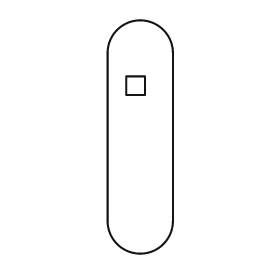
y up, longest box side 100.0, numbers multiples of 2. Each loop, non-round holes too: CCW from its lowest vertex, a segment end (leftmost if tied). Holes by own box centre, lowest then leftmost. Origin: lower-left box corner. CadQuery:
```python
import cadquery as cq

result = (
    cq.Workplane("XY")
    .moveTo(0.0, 14.0)
    .threePointArc((14.0, 0.0), (28.0, 14.0))
    .lineTo(28.0, 86.0)
    .threePointArc((14.0, 100.0), (0.0, 86.0))
    .close()
    .moveTo(8.0, 68.0)
    .lineTo(16.0, 68.0)
    .lineTo(16.0, 76.0)
    .lineTo(8.0, 76.0)
    .close()
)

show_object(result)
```